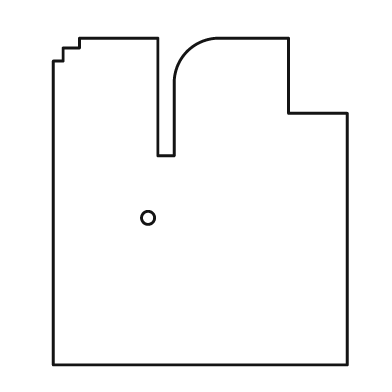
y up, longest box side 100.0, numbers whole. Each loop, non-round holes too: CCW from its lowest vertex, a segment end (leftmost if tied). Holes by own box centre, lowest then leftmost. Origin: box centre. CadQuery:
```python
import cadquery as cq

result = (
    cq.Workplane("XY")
    .moveTo(-45.0, -50.0)
    .lineTo(45.0, -50.0)
    .lineTo(45.0, 27.0)
    .lineTo(27.0, 27.0)
    .lineTo(27.0, 50.0)
    .lineTo(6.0, 50.0)
    .threePointArc((-4.0, 46.0), (-8.0, 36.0))
    .lineTo(-8.0, 14.0)
    .lineTo(-13.0, 14.0)
    .lineTo(-13.0, 50.0)
    .lineTo(-37.0, 50.0)
    .lineTo(-37.0, 47.0)
    .lineTo(-42.0, 47.0)
    .lineTo(-42.0, 43.0)
    .lineTo(-45.0, 43.0)
    .close()
    .moveTo(-16.0, -5.0)
    .circle(2.0)
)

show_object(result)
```